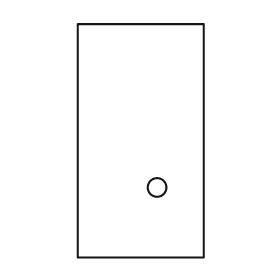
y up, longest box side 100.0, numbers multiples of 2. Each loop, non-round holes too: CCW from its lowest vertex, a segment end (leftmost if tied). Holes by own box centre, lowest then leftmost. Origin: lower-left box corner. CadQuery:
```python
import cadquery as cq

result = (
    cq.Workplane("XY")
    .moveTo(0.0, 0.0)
    .lineTo(54.0, 0.0)
    .lineTo(54.0, 100.0)
    .lineTo(0.0, 100.0)
    .close()
    .moveTo(34.0, 30.0)
    .circle(4.0)
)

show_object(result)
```